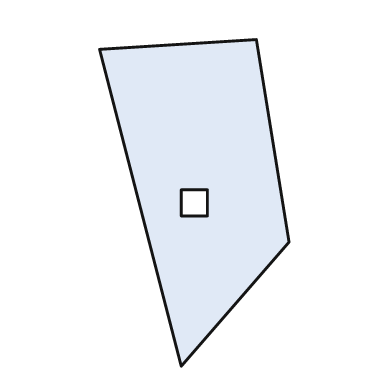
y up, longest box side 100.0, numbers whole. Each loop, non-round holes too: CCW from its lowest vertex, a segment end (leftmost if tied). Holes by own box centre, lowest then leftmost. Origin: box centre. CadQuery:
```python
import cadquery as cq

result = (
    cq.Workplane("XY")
    .moveTo(-4.0, -50.0)
    .lineTo(29.0, -12.0)
    .lineTo(19.0, 50.0)
    .lineTo(-29.0, 47.0)
    .close()
    .moveTo(-4.0, -4.0)
    .lineTo(4.0, -4.0)
    .lineTo(4.0, 4.0)
    .lineTo(-4.0, 4.0)
    .close()
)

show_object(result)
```